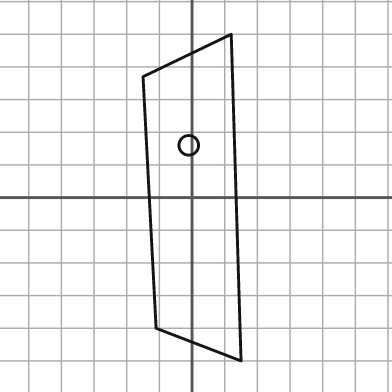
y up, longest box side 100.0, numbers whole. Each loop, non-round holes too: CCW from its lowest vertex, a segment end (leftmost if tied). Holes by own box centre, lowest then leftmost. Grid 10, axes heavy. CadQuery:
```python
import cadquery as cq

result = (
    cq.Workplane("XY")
    .moveTo(15.0, -50.0)
    .lineTo(12.0, 50.0)
    .lineTo(-15.0, 37.0)
    .lineTo(-11.0, -40.0)
    .close()
    .moveTo(-1.0, 16.0)
    .circle(3.0)
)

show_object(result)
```